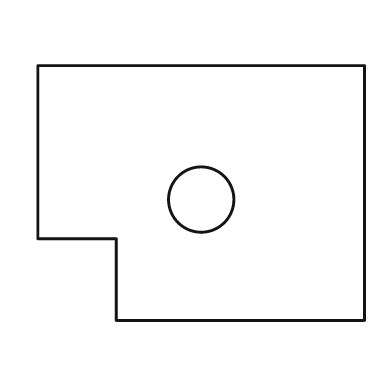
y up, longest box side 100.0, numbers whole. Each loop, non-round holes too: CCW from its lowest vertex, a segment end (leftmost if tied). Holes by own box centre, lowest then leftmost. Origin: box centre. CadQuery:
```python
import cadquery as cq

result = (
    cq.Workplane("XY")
    .moveTo(-26.0, -39.0)
    .lineTo(50.0, -39.0)
    .lineTo(50.0, 39.0)
    .lineTo(-50.0, 39.0)
    .lineTo(-50.0, -14.0)
    .lineTo(-26.0, -14.0)
    .close()
    .moveTo(0.0, -2.0)
    .circle(10.0)
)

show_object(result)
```